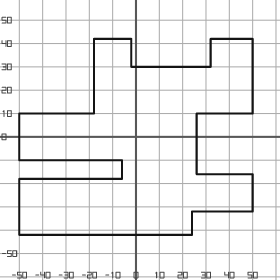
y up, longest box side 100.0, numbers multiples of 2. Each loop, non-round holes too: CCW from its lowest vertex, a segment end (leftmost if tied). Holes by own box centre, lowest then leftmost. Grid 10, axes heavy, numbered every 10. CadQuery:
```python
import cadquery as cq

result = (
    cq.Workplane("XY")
    .moveTo(-50.0, -42.0)
    .lineTo(24.0, -42.0)
    .lineTo(24.0, -32.0)
    .lineTo(50.0, -32.0)
    .lineTo(50.0, -16.0)
    .lineTo(26.0, -16.0)
    .lineTo(26.0, 10.0)
    .lineTo(50.0, 10.0)
    .lineTo(50.0, 42.0)
    .lineTo(32.0, 42.0)
    .lineTo(32.0, 30.0)
    .lineTo(-2.0, 30.0)
    .lineTo(-2.0, 42.0)
    .lineTo(-18.0, 42.0)
    .lineTo(-18.0, 10.0)
    .lineTo(-50.0, 10.0)
    .lineTo(-50.0, -10.0)
    .lineTo(-6.0, -10.0)
    .lineTo(-6.0, -18.0)
    .lineTo(-50.0, -18.0)
    .close()
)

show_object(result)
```